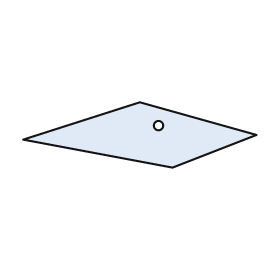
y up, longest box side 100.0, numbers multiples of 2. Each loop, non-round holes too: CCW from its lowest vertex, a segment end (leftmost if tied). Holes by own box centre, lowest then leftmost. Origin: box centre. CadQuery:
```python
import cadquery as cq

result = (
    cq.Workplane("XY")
    .moveTo(14.0, -14.0)
    .lineTo(50.0, 0.0)
    .lineTo(0.0, 14.0)
    .lineTo(-50.0, -2.0)
    .close()
    .moveTo(8.0, 4.0)
    .circle(2.0)
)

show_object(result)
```